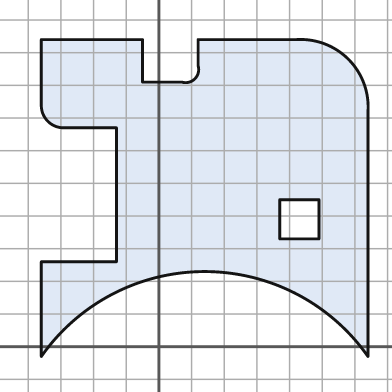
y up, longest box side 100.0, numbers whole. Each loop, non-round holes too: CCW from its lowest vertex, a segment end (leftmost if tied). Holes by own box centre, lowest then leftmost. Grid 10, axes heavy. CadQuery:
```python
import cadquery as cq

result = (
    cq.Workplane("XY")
    .moveTo(-36.0, -3.0)
    .threePointArc((14.0, 23.0), (64.0, -3.0))
    .lineTo(64.0, 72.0)
    .threePointArc((58.0, 88.0), (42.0, 94.0))
    .lineTo(12.0, 94.0)
    .lineTo(12.0, 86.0)
    .threePointArc((11.0, 82.0), (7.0, 81.0))
    .lineTo(-5.0, 81.0)
    .lineTo(-5.0, 94.0)
    .lineTo(-36.0, 94.0)
    .lineTo(-36.0, 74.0)
    .threePointArc((-34.0, 69.0), (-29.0, 67.0))
    .lineTo(-13.0, 67.0)
    .lineTo(-13.0, 26.0)
    .lineTo(-36.0, 26.0)
    .close()
    .moveTo(37.0, 33.0)
    .lineTo(49.0, 33.0)
    .lineTo(49.0, 45.0)
    .lineTo(37.0, 45.0)
    .close()
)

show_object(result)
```